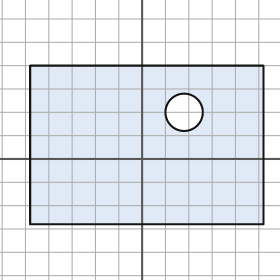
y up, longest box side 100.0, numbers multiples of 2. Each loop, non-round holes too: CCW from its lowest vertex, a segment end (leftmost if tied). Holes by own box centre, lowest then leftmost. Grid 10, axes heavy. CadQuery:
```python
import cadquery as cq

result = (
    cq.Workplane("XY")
    .moveTo(-48.0, -28.0)
    .lineTo(52.0, -28.0)
    .lineTo(52.0, 40.0)
    .lineTo(-48.0, 40.0)
    .close()
    .moveTo(18.0, 20.0)
    .circle(8.0)
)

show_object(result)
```